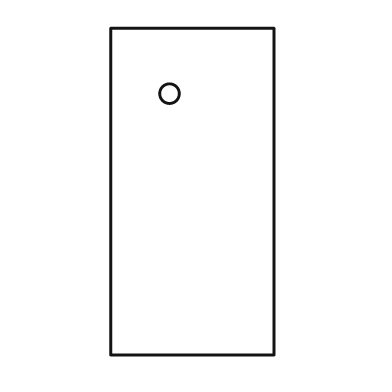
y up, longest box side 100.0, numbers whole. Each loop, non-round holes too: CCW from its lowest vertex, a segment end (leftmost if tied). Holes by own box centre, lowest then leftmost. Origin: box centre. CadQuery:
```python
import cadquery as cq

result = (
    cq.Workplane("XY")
    .moveTo(-25.0, -50.0)
    .lineTo(25.0, -50.0)
    .lineTo(25.0, 50.0)
    .lineTo(-25.0, 50.0)
    .close()
    .moveTo(-7.0, 30.0)
    .circle(3.0)
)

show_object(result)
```